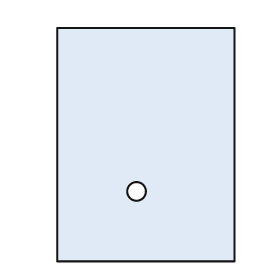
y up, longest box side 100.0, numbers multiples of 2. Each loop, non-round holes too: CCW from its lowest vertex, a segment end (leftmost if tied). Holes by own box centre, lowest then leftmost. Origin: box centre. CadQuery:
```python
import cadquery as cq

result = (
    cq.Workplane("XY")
    .moveTo(-38.0, -50.0)
    .lineTo(38.0, -50.0)
    .lineTo(38.0, 50.0)
    .lineTo(-38.0, 50.0)
    .close()
    .moveTo(-4.0, -20.0)
    .circle(4.0)
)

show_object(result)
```